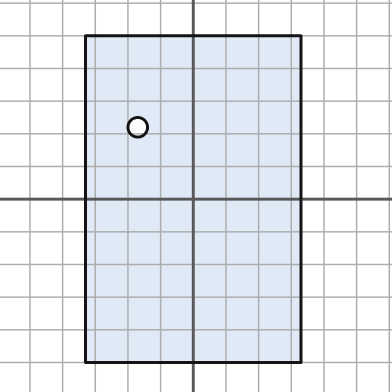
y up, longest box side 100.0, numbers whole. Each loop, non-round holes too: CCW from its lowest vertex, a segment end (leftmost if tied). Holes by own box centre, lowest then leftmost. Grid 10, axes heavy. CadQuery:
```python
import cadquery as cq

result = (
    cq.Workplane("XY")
    .moveTo(-33.0, -50.0)
    .lineTo(33.0, -50.0)
    .lineTo(33.0, 50.0)
    .lineTo(-33.0, 50.0)
    .close()
    .moveTo(-17.0, 22.0)
    .circle(3.0)
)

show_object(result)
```